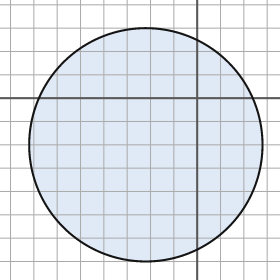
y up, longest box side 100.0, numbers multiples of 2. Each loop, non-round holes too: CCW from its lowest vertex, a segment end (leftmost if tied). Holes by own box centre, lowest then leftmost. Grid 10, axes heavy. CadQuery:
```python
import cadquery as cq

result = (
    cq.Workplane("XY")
    .moveTo(-22.0, -20.0)
    .circle(50.0)
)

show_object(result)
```